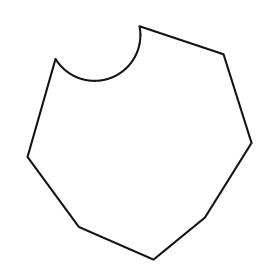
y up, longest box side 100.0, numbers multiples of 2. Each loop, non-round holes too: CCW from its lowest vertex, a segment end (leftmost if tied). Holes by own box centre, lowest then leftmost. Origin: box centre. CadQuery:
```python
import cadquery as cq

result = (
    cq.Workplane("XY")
    .moveTo(6.0, -50.0)
    .lineTo(28.0, -32.0)
    .lineTo(48.0, 0.0)
    .lineTo(36.0, 38.0)
    .lineTo(0.0, 50.0)
    .threePointArc((-12.0, 28.0), (-36.0, 36.0))
    .lineTo(-48.0, -6.0)
    .lineTo(-26.0, -36.0)
    .close()
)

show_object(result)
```